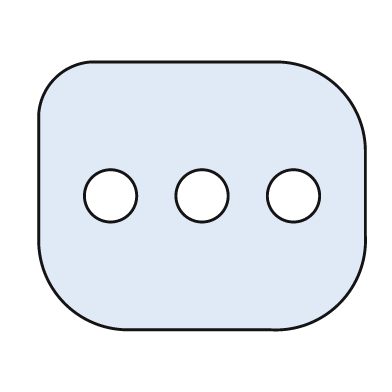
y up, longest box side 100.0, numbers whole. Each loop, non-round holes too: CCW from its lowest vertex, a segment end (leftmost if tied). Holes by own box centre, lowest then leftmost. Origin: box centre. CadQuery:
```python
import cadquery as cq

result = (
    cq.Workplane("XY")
    .moveTo(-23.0, -41.0)
    .lineTo(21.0, -41.0)
    .threePointArc((42.0, -33.0), (50.0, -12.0))
    .lineTo(50.0, 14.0)
    .threePointArc((42.0, 33.0), (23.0, 41.0))
    .lineTo(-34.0, 41.0)
    .threePointArc((-45.0, 36.0), (-50.0, 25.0))
    .lineTo(-50.0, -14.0)
    .threePointArc((-42.0, -33.0), (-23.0, -41.0))
    .close()
    .moveTo(-28.0, 0.0)
    .circle(8.0)
    .moveTo(0.0, 0.0)
    .circle(8.0)
    .moveTo(28.0, 0.0)
    .circle(8.0)
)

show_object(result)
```